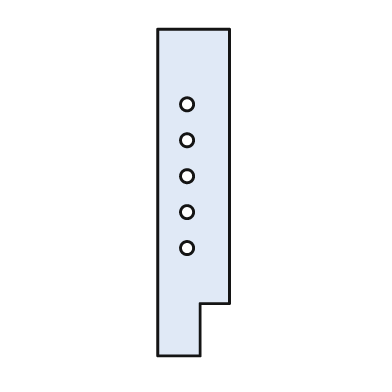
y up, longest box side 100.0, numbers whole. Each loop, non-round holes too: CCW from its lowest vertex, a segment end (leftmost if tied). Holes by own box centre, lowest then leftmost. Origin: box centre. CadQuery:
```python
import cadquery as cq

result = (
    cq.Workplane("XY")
    .moveTo(-11.0, -50.0)
    .lineTo(2.0, -50.0)
    .lineTo(2.0, -34.0)
    .lineTo(11.0, -34.0)
    .lineTo(11.0, 50.0)
    .lineTo(-11.0, 50.0)
    .close()
    .moveTo(-2.0, -17.0)
    .circle(2.0)
    .moveTo(-2.0, -6.0)
    .circle(2.0)
    .moveTo(-2.0, 5.0)
    .circle(2.0)
    .moveTo(-2.0, 16.0)
    .circle(2.0)
    .moveTo(-2.0, 27.0)
    .circle(2.0)
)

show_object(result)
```